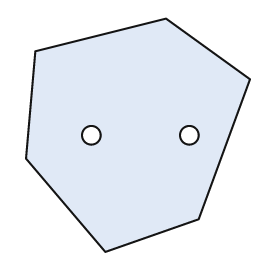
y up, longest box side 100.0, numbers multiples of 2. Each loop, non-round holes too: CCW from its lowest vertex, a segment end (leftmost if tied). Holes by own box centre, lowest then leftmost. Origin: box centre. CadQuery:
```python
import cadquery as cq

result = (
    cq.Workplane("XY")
    .moveTo(-14.0, -50.0)
    .lineTo(26.0, -36.0)
    .lineTo(48.0, 24.0)
    .lineTo(12.0, 50.0)
    .lineTo(-44.0, 36.0)
    .lineTo(-48.0, -10.0)
    .close()
    .moveTo(-20.0, 0.0)
    .circle(4.0)
    .moveTo(22.0, 0.0)
    .circle(4.0)
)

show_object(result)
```